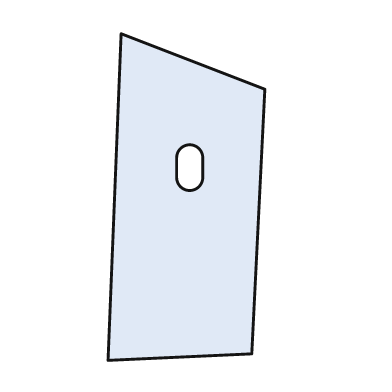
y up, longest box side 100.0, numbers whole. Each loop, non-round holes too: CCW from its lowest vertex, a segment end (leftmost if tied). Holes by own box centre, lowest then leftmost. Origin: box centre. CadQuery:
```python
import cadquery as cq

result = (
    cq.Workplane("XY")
    .moveTo(-24.0, -50.0)
    .lineTo(20.0, -48.0)
    .lineTo(24.0, 33.0)
    .lineTo(-20.0, 50.0)
    .close()
    .moveTo(-3.0, 6.0)
    .threePointArc((1.0, 2.0), (5.0, 6.0))
    .lineTo(5.0, 12.0)
    .threePointArc((1.0, 16.0), (-3.0, 12.0))
    .close()
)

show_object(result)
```